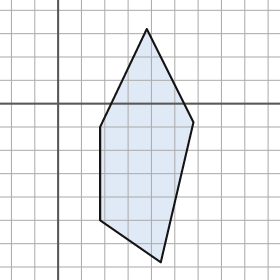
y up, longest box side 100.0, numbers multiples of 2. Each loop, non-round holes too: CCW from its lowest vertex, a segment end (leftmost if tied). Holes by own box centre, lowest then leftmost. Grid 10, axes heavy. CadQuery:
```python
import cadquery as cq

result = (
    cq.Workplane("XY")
    .moveTo(44.0, -68.0)
    .lineTo(58.0, -8.0)
    .lineTo(38.0, 32.0)
    .lineTo(18.0, -10.0)
    .lineTo(18.0, -50.0)
    .close()
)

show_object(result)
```